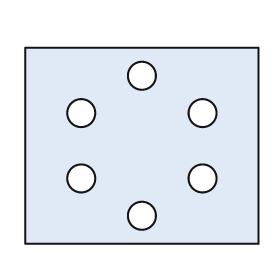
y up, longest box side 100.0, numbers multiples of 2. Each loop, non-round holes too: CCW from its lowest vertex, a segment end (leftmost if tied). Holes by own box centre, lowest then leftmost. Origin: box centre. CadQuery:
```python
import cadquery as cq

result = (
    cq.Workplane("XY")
    .moveTo(-50.0, -42.0)
    .lineTo(50.0, -42.0)
    .lineTo(50.0, 42.0)
    .lineTo(-50.0, 42.0)
    .close()
    .moveTo(0.0, -30.0)
    .circle(6.0)
    .moveTo(-26.0, -14.0)
    .circle(6.0)
    .moveTo(26.0, -14.0)
    .circle(6.0)
    .moveTo(-26.0, 14.0)
    .circle(6.0)
    .moveTo(26.0, 14.0)
    .circle(6.0)
    .moveTo(0.0, 30.0)
    .circle(6.0)
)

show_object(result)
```